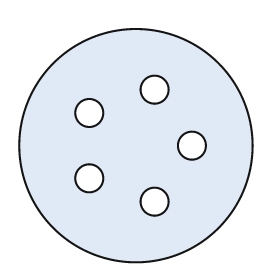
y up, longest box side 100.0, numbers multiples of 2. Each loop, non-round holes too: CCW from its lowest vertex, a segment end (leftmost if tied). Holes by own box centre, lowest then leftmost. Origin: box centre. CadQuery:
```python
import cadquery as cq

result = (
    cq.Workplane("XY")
    .moveTo(0.0, 0.0)
    .circle(50.0)
    .moveTo(8.0, -24.0)
    .circle(6.0)
    .moveTo(-20.0, -14.0)
    .circle(6.0)
    .moveTo(24.0, 0.0)
    .circle(6.0)
    .moveTo(-20.0, 14.0)
    .circle(6.0)
    .moveTo(8.0, 24.0)
    .circle(6.0)
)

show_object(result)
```